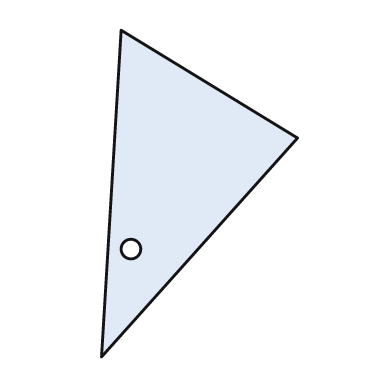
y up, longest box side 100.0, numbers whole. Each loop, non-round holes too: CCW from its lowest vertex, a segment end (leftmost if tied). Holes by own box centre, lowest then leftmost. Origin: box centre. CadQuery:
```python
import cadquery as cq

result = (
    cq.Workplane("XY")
    .moveTo(-30.0, -50.0)
    .lineTo(30.0, 17.0)
    .lineTo(-24.0, 50.0)
    .close()
    .moveTo(-21.0, -17.0)
    .circle(3.0)
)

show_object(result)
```